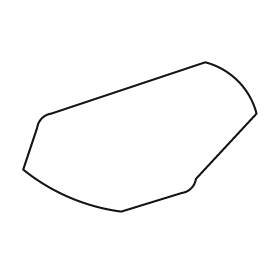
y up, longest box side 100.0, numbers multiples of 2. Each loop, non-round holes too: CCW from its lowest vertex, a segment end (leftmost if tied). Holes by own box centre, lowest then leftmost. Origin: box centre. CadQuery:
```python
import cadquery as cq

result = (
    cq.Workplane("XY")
    .moveTo(-8.0, -32.0)
    .lineTo(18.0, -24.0)
    .threePointArc((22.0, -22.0), (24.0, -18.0))
    .lineTo(50.0, 10.0)
    .threePointArc((42.0, 24.0), (28.0, 32.0))
    .lineTo(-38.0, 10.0)
    .threePointArc((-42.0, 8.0), (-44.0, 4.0))
    .lineTo(-50.0, -14.0)
    .threePointArc((-30.0, -26.0), (-8.0, -32.0))
    .close()
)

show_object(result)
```